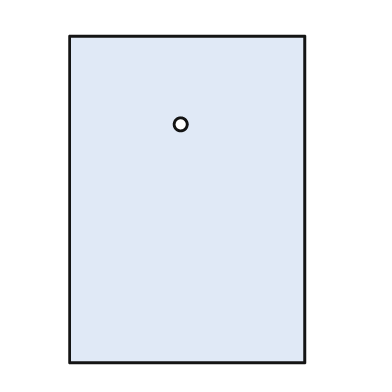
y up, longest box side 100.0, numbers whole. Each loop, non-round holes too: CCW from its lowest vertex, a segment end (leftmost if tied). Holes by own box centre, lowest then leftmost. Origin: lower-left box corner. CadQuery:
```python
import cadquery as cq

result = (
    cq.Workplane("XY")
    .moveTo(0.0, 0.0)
    .lineTo(72.0, 0.0)
    .lineTo(72.0, 100.0)
    .lineTo(0.0, 100.0)
    .close()
    .moveTo(34.0, 73.0)
    .circle(2.0)
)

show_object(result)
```